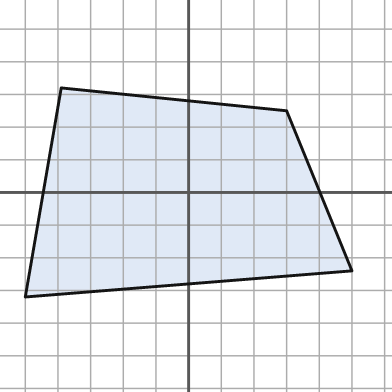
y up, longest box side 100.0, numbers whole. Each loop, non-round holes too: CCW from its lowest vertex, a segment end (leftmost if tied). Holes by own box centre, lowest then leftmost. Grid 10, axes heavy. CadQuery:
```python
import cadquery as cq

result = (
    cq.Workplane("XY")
    .moveTo(-50.0, -32.0)
    .lineTo(50.0, -24.0)
    .lineTo(30.0, 25.0)
    .lineTo(-39.0, 32.0)
    .close()
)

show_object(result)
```